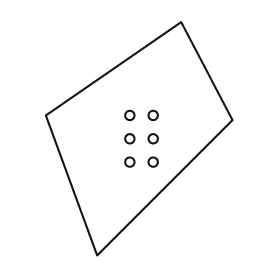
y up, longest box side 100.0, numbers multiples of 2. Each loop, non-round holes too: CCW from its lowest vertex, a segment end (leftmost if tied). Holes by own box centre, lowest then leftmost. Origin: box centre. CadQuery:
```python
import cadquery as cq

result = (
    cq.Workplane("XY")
    .moveTo(-18.0, -50.0)
    .lineTo(40.0, 8.0)
    .lineTo(18.0, 50.0)
    .lineTo(-40.0, 10.0)
    .close()
    .moveTo(-4.0, -10.0)
    .circle(2.0)
    .moveTo(6.0, -10.0)
    .circle(2.0)
    .moveTo(-4.0, 0.0)
    .circle(2.0)
    .moveTo(6.0, 0.0)
    .circle(2.0)
    .moveTo(-4.0, 10.0)
    .circle(2.0)
    .moveTo(6.0, 10.0)
    .circle(2.0)
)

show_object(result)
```